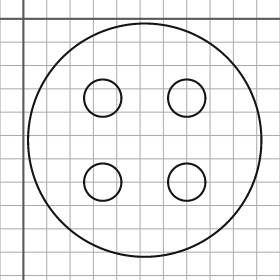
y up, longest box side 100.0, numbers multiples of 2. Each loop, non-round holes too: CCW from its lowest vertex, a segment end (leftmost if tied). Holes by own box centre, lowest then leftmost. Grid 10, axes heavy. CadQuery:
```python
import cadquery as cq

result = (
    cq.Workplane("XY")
    .moveTo(52.0, -52.0)
    .circle(50.0)
    .moveTo(34.0, -70.0)
    .circle(8.0)
    .moveTo(70.0, -70.0)
    .circle(8.0)
    .moveTo(34.0, -34.0)
    .circle(8.0)
    .moveTo(70.0, -34.0)
    .circle(8.0)
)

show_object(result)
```